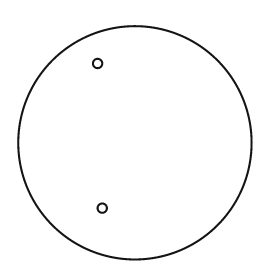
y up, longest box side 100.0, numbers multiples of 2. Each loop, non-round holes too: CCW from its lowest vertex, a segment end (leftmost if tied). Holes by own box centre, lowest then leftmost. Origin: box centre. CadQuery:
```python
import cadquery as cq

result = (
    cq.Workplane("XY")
    .moveTo(0.0, 0.0)
    .circle(50.0)
    .moveTo(-14.0, -28.0)
    .circle(2.0)
    .moveTo(-16.0, 34.0)
    .circle(2.0)
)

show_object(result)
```